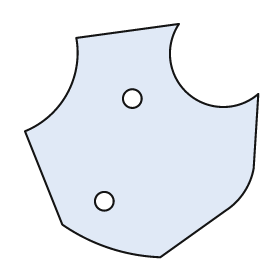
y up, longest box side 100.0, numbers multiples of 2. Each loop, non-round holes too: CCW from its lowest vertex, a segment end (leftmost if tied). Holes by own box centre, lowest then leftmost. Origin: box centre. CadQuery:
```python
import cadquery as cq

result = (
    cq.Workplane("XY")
    .moveTo(8.0, -50.0)
    .lineTo(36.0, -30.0)
    .threePointArc((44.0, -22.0), (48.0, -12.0))
    .lineTo(50.0, 20.0)
    .threePointArc((20.0, 20.0), (16.0, 50.0))
    .lineTo(-28.0, 44.0)
    .threePointArc((-32.0, 20.0), (-50.0, 4.0))
    .lineTo(-34.0, -36.0)
    .threePointArc((-14.0, -46.0), (8.0, -50.0))
    .close()
    .moveTo(-16.0, -26.0)
    .circle(4.0)
    .moveTo(-4.0, 18.0)
    .circle(4.0)
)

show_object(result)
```